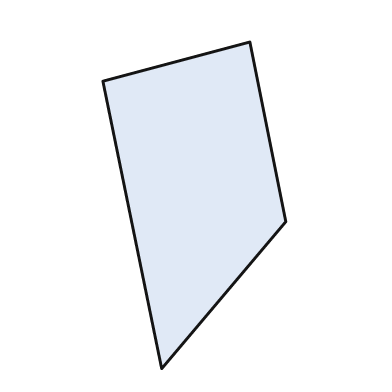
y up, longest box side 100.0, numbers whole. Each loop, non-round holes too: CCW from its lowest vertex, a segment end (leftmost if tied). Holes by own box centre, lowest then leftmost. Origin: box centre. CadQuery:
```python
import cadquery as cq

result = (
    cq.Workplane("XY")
    .moveTo(-10.0, -50.0)
    .lineTo(28.0, -5.0)
    .lineTo(17.0, 50.0)
    .lineTo(-28.0, 38.0)
    .close()
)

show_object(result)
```